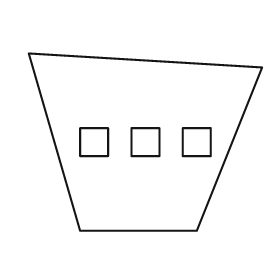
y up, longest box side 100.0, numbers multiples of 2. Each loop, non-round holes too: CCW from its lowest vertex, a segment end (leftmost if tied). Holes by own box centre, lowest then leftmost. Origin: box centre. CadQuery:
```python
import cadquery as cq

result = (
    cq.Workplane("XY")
    .moveTo(-28.0, -38.0)
    .lineTo(22.0, -38.0)
    .lineTo(50.0, 32.0)
    .lineTo(-50.0, 38.0)
    .close()
    .moveTo(-28.0, -6.0)
    .lineTo(-16.0, -6.0)
    .lineTo(-16.0, 6.0)
    .lineTo(-28.0, 6.0)
    .close()
    .moveTo(-6.0, -6.0)
    .lineTo(6.0, -6.0)
    .lineTo(6.0, 6.0)
    .lineTo(-6.0, 6.0)
    .close()
    .moveTo(16.0, -6.0)
    .lineTo(28.0, -6.0)
    .lineTo(28.0, 6.0)
    .lineTo(16.0, 6.0)
    .close()
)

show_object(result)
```